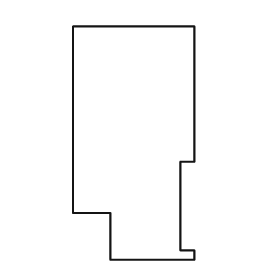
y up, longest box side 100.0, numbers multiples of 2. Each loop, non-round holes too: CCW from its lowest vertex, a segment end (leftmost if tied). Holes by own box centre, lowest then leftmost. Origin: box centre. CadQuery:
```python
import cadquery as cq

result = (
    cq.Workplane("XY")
    .moveTo(-10.0, -50.0)
    .lineTo(26.0, -50.0)
    .lineTo(26.0, -46.0)
    .lineTo(20.0, -46.0)
    .lineTo(20.0, -8.0)
    .lineTo(26.0, -8.0)
    .lineTo(26.0, 50.0)
    .lineTo(-26.0, 50.0)
    .lineTo(-26.0, -30.0)
    .lineTo(-10.0, -30.0)
    .close()
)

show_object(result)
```